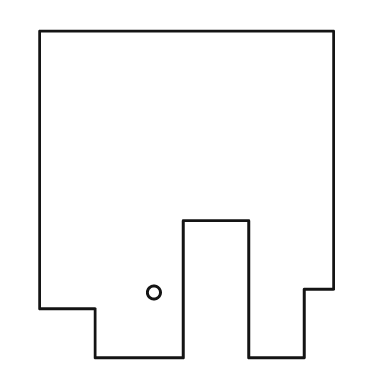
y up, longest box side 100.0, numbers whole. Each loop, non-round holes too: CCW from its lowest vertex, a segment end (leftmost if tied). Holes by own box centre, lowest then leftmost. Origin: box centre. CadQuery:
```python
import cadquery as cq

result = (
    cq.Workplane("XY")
    .moveTo(-28.0, -50.0)
    .lineTo(-1.0, -50.0)
    .lineTo(-1.0, -8.0)
    .lineTo(19.0, -8.0)
    .lineTo(19.0, -50.0)
    .lineTo(36.0, -50.0)
    .lineTo(36.0, -29.0)
    .lineTo(45.0, -29.0)
    .lineTo(45.0, 50.0)
    .lineTo(-45.0, 50.0)
    .lineTo(-45.0, -35.0)
    .lineTo(-28.0, -35.0)
    .close()
    .moveTo(-10.0, -30.0)
    .circle(2.0)
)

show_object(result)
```